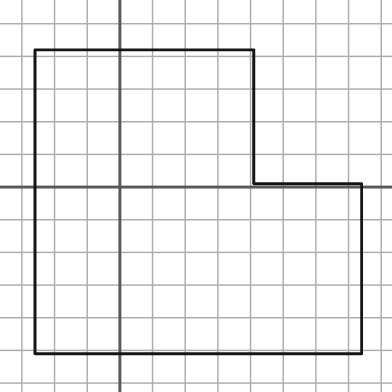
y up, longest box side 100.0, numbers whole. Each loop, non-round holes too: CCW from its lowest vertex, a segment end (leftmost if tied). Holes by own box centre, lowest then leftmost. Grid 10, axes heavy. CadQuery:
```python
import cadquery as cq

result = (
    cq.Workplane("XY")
    .moveTo(-26.0, -51.0)
    .lineTo(74.0, -51.0)
    .lineTo(74.0, 1.0)
    .lineTo(41.0, 1.0)
    .lineTo(41.0, 42.0)
    .lineTo(-26.0, 42.0)
    .close()
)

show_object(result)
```